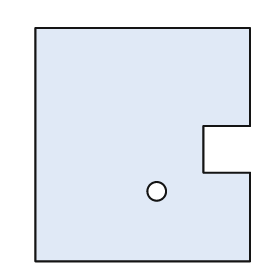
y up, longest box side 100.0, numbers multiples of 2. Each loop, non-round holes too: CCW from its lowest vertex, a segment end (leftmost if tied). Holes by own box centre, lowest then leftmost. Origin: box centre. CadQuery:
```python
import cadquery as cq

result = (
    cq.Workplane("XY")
    .moveTo(-46.0, -50.0)
    .lineTo(46.0, -50.0)
    .lineTo(46.0, -12.0)
    .lineTo(26.0, -12.0)
    .lineTo(26.0, 8.0)
    .lineTo(46.0, 8.0)
    .lineTo(46.0, 50.0)
    .lineTo(-46.0, 50.0)
    .close()
    .moveTo(6.0, -20.0)
    .circle(4.0)
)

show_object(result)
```